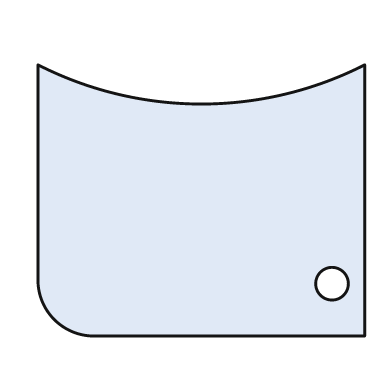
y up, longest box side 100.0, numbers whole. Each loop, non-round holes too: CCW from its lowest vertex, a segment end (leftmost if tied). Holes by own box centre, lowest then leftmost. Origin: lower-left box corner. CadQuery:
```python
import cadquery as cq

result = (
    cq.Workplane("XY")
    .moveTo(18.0, 0.0)
    .lineTo(100.0, 0.0)
    .lineTo(100.0, 83.0)
    .threePointArc((50.0, 71.0), (0.0, 83.0))
    .lineTo(0.0, 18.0)
    .threePointArc((5.0, 5.0), (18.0, 0.0))
    .close()
    .moveTo(90.0, 16.0)
    .circle(5.0)
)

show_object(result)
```